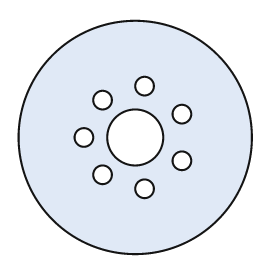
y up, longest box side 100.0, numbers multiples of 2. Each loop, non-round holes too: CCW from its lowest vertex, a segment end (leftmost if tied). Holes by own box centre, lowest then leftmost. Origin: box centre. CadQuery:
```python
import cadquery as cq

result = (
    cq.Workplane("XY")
    .moveTo(0.0, 0.0)
    .circle(50.0)
    .moveTo(4.0, -22.0)
    .circle(4.0)
    .moveTo(-14.0, -16.0)
    .circle(4.0)
    .moveTo(20.0, -10.0)
    .circle(4.0)
    .moveTo(-22.0, 0.0)
    .circle(4.0)
    .moveTo(0.0, 0.0)
    .circle(12.0)
    .moveTo(20.0, 10.0)
    .circle(4.0)
    .moveTo(-14.0, 16.0)
    .circle(4.0)
    .moveTo(4.0, 22.0)
    .circle(4.0)
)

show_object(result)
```